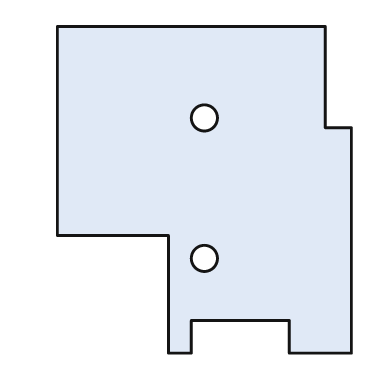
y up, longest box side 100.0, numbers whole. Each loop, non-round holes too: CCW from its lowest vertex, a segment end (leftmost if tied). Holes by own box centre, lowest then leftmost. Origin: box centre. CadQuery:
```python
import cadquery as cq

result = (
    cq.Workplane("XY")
    .moveTo(-11.0, -50.0)
    .lineTo(-4.0, -50.0)
    .lineTo(-4.0, -40.0)
    .lineTo(26.0, -40.0)
    .lineTo(26.0, -50.0)
    .lineTo(45.0, -50.0)
    .lineTo(45.0, 19.0)
    .lineTo(37.0, 19.0)
    .lineTo(37.0, 50.0)
    .lineTo(-45.0, 50.0)
    .lineTo(-45.0, -14.0)
    .lineTo(-11.0, -14.0)
    .close()
    .moveTo(0.0, -21.0)
    .circle(4.0)
    .moveTo(0.0, 22.0)
    .circle(4.0)
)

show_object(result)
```